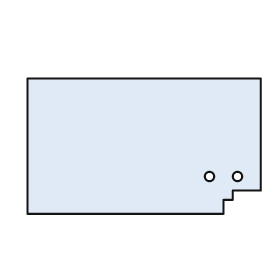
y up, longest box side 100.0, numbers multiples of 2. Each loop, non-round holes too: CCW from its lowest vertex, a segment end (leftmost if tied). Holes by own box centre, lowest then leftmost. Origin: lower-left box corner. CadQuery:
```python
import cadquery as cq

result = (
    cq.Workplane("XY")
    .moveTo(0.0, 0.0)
    .lineTo(84.0, 0.0)
    .lineTo(84.0, 6.0)
    .lineTo(88.0, 6.0)
    .lineTo(88.0, 10.0)
    .lineTo(100.0, 10.0)
    .lineTo(100.0, 58.0)
    .lineTo(0.0, 58.0)
    .close()
    .moveTo(78.0, 16.0)
    .circle(2.0)
    .moveTo(90.0, 16.0)
    .circle(2.0)
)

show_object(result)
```